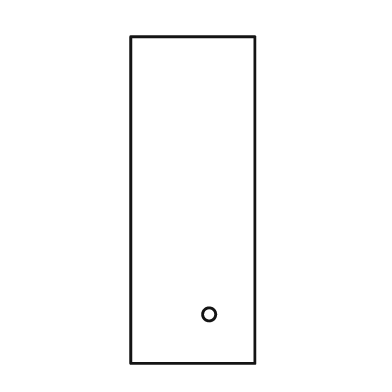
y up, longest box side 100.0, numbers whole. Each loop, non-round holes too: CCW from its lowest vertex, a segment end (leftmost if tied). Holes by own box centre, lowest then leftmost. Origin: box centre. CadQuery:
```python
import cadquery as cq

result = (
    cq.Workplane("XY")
    .moveTo(-19.0, -50.0)
    .lineTo(19.0, -50.0)
    .lineTo(19.0, 50.0)
    .lineTo(-19.0, 50.0)
    .close()
    .moveTo(5.0, -35.0)
    .circle(2.0)
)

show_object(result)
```